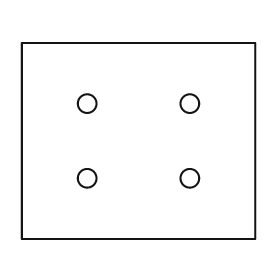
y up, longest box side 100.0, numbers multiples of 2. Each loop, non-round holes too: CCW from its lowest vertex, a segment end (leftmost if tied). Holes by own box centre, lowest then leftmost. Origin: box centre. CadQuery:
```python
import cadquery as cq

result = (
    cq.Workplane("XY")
    .moveTo(-50.0, -42.0)
    .lineTo(50.0, -42.0)
    .lineTo(50.0, 42.0)
    .lineTo(-50.0, 42.0)
    .close()
    .moveTo(-22.0, -16.0)
    .circle(4.0)
    .moveTo(22.0, -16.0)
    .circle(4.0)
    .moveTo(-22.0, 16.0)
    .circle(4.0)
    .moveTo(22.0, 16.0)
    .circle(4.0)
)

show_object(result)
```